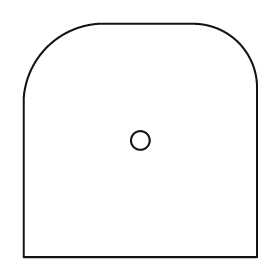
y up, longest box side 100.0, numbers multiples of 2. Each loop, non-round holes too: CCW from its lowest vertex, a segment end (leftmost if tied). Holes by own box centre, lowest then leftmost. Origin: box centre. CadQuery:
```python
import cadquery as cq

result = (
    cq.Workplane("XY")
    .moveTo(-50.0, -50.0)
    .lineTo(50.0, -50.0)
    .lineTo(50.0, 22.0)
    .threePointArc((42.0, 42.0), (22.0, 50.0))
    .lineTo(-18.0, 50.0)
    .threePointArc((-40.0, 40.0), (-50.0, 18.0))
    .close()
    .moveTo(0.0, 0.0)
    .circle(4.0)
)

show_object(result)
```